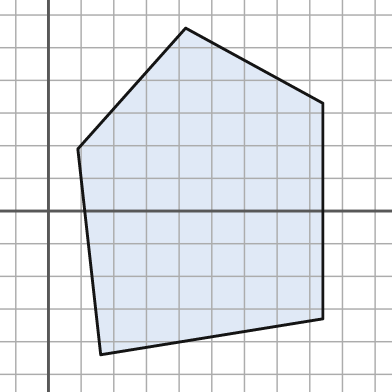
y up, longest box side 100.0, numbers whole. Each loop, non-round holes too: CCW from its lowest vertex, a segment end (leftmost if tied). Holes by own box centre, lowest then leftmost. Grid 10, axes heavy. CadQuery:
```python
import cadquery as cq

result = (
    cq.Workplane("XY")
    .moveTo(16.0, -44.0)
    .lineTo(84.0, -33.0)
    .lineTo(84.0, 33.0)
    .lineTo(42.0, 56.0)
    .lineTo(9.0, 19.0)
    .close()
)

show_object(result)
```